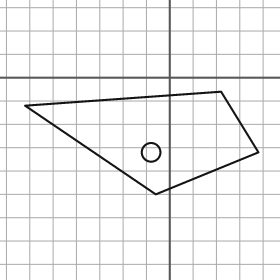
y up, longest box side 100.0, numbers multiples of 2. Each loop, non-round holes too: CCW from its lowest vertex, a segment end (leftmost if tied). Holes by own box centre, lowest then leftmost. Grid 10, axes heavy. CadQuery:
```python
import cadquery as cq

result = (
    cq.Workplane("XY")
    .moveTo(-6.0, -50.0)
    .lineTo(38.0, -32.0)
    .lineTo(22.0, -6.0)
    .lineTo(-62.0, -12.0)
    .close()
    .moveTo(-8.0, -32.0)
    .circle(4.0)
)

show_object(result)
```